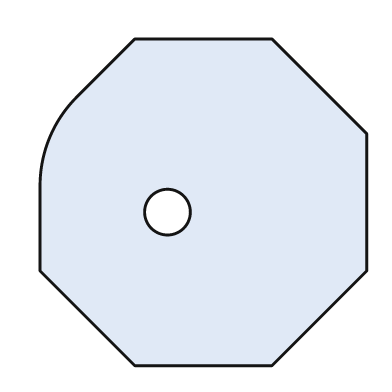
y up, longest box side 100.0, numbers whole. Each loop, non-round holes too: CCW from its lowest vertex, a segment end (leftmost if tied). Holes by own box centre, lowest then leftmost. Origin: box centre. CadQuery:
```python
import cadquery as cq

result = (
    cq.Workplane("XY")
    .moveTo(-21.0, -50.0)
    .lineTo(21.0, -50.0)
    .lineTo(50.0, -21.0)
    .lineTo(50.0, 21.0)
    .lineTo(21.0, 50.0)
    .lineTo(-21.0, 50.0)
    .lineTo(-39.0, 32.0)
    .threePointArc((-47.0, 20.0), (-50.0, 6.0))
    .lineTo(-50.0, -21.0)
    .close()
    .moveTo(-11.0, -3.0)
    .circle(7.0)
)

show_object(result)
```